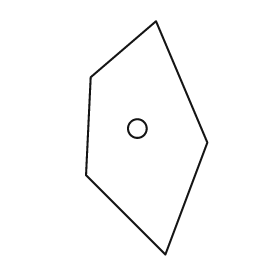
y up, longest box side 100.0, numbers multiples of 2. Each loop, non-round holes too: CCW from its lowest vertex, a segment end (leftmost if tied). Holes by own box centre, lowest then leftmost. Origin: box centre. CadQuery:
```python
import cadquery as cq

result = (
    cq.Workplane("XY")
    .moveTo(8.0, -50.0)
    .lineTo(26.0, -2.0)
    .lineTo(4.0, 50.0)
    .lineTo(-24.0, 26.0)
    .lineTo(-26.0, -16.0)
    .close()
    .moveTo(-4.0, 4.0)
    .circle(4.0)
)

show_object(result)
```